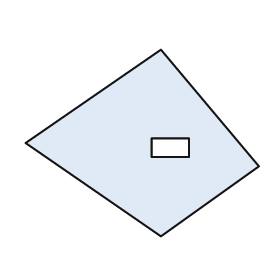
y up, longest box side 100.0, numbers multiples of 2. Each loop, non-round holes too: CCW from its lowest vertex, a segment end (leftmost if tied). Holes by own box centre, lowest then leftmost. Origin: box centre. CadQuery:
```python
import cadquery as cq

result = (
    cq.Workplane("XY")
    .moveTo(8.0, -40.0)
    .lineTo(50.0, -10.0)
    .lineTo(8.0, 40.0)
    .lineTo(-50.0, 0.0)
    .close()
    .moveTo(4.0, -6.0)
    .lineTo(20.0, -6.0)
    .lineTo(20.0, 2.0)
    .lineTo(4.0, 2.0)
    .close()
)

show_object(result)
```